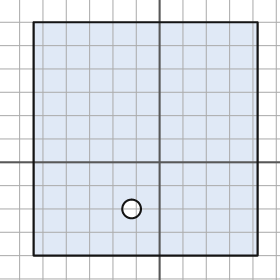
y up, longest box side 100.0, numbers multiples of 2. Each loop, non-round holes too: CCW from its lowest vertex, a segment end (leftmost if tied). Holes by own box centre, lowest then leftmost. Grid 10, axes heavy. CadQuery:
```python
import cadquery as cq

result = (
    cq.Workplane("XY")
    .moveTo(-54.0, -40.0)
    .lineTo(42.0, -40.0)
    .lineTo(42.0, 60.0)
    .lineTo(-54.0, 60.0)
    .close()
    .moveTo(-12.0, -20.0)
    .circle(4.0)
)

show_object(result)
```